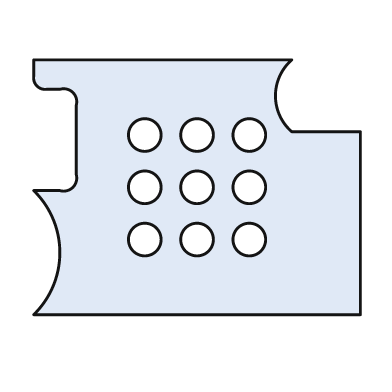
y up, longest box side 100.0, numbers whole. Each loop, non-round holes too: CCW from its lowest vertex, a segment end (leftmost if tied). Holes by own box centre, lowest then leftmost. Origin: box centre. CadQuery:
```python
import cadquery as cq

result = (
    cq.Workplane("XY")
    .moveTo(-50.0, -39.0)
    .lineTo(50.0, -39.0)
    .lineTo(50.0, 17.0)
    .lineTo(29.0, 17.0)
    .threePointArc((24.0, 28.0), (29.0, 39.0))
    .lineTo(-50.0, 39.0)
    .lineTo(-50.0, 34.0)
    .threePointArc((-49.0, 31.0), (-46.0, 30.0))
    .lineTo(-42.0, 30.0)
    .threePointArc((-38.0, 29.0), (-37.0, 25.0))
    .lineTo(-37.0, 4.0)
    .threePointArc((-38.0, 0.0), (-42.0, -1.0))
    .lineTo(-50.0, -1.0)
    .threePointArc((-42.0, -20.0), (-50.0, -39.0))
    .close()
    .moveTo(-16.0, -16.0)
    .circle(5.0)
    .moveTo(0.0, -16.0)
    .circle(5.0)
    .moveTo(16.0, -16.0)
    .circle(5.0)
    .moveTo(-16.0, 0.0)
    .circle(5.0)
    .moveTo(0.0, 0.0)
    .circle(5.0)
    .moveTo(16.0, 0.0)
    .circle(5.0)
    .moveTo(-16.0, 16.0)
    .circle(5.0)
    .moveTo(0.0, 16.0)
    .circle(5.0)
    .moveTo(16.0, 16.0)
    .circle(5.0)
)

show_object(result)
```